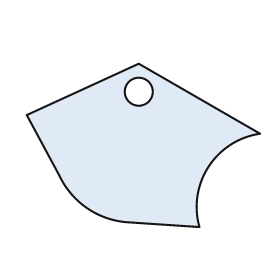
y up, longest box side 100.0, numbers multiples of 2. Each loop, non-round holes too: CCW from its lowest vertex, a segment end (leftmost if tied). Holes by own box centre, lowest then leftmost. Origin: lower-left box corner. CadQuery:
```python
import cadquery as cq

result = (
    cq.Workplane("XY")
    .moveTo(74.0, 0.0)
    .threePointArc((78.0, 26.0), (100.0, 40.0))
    .lineTo(48.0, 70.0)
    .lineTo(0.0, 48.0)
    .lineTo(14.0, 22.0)
    .threePointArc((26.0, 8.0), (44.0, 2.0))
    .close()
    .moveTo(48.0, 58.0)
    .circle(6.0)
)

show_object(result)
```